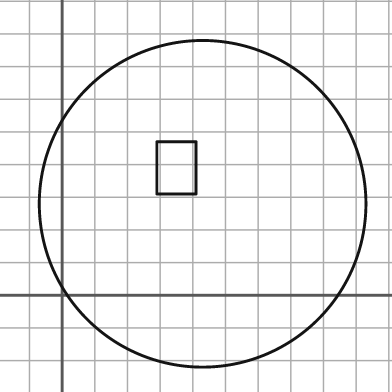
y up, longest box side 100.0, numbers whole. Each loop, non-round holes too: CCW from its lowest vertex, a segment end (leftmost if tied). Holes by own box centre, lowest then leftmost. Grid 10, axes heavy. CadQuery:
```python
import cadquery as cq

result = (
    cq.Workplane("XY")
    .moveTo(43.0, 28.0)
    .circle(50.0)
    .moveTo(29.0, 31.0)
    .lineTo(41.0, 31.0)
    .lineTo(41.0, 47.0)
    .lineTo(29.0, 47.0)
    .close()
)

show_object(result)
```